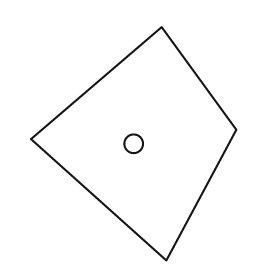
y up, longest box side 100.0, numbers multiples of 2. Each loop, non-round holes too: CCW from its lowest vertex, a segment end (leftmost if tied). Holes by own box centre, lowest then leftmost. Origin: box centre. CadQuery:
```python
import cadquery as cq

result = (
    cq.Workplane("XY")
    .moveTo(14.0, -50.0)
    .lineTo(44.0, 6.0)
    .lineTo(12.0, 50.0)
    .lineTo(-44.0, 2.0)
    .close()
    .moveTo(0.0, 0.0)
    .circle(4.0)
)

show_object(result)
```